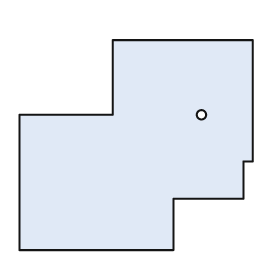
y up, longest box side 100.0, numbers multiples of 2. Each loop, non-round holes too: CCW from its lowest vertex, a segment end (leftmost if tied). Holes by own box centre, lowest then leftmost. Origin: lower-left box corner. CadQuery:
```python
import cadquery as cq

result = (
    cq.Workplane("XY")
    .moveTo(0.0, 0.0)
    .lineTo(66.0, 0.0)
    .lineTo(66.0, 22.0)
    .lineTo(96.0, 22.0)
    .lineTo(96.0, 38.0)
    .lineTo(100.0, 38.0)
    .lineTo(100.0, 90.0)
    .lineTo(40.0, 90.0)
    .lineTo(40.0, 58.0)
    .lineTo(0.0, 58.0)
    .close()
    .moveTo(78.0, 58.0)
    .circle(2.0)
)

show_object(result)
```